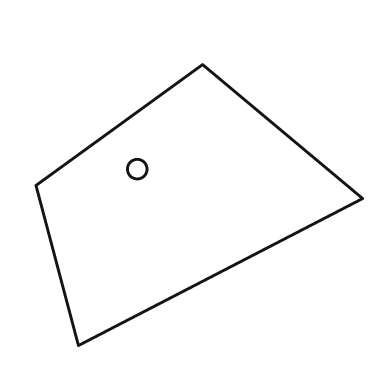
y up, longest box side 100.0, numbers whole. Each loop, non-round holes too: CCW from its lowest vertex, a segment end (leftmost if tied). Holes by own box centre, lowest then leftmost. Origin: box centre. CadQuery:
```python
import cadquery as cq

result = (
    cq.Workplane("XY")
    .moveTo(-37.0, -43.0)
    .lineTo(50.0, 2.0)
    .lineTo(1.0, 43.0)
    .lineTo(-50.0, 6.0)
    .close()
    .moveTo(-19.0, 11.0)
    .circle(3.0)
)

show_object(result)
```